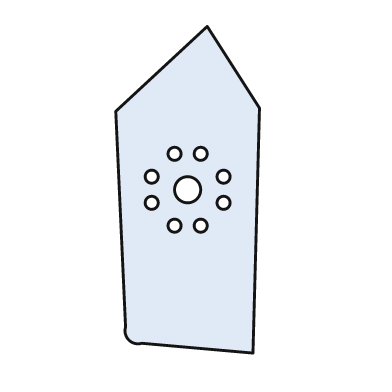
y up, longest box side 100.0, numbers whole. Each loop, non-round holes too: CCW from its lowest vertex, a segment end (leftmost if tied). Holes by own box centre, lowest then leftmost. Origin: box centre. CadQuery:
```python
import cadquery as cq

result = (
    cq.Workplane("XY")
    .moveTo(20.0, -50.0)
    .lineTo(22.0, 25.0)
    .lineTo(6.0, 50.0)
    .lineTo(-22.0, 24.0)
    .lineTo(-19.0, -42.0)
    .threePointArc((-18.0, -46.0), (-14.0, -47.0))
    .close()
    .moveTo(-4.0, -11.0)
    .circle(2.0)
    .moveTo(4.0, -11.0)
    .circle(2.0)
    .moveTo(-11.0, -4.0)
    .circle(2.0)
    .moveTo(11.0, -4.0)
    .circle(2.0)
    .moveTo(0.0, 0.0)
    .circle(4.0)
    .moveTo(-11.0, 4.0)
    .circle(2.0)
    .moveTo(11.0, 4.0)
    .circle(2.0)
    .moveTo(-4.0, 11.0)
    .circle(2.0)
    .moveTo(4.0, 11.0)
    .circle(2.0)
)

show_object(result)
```